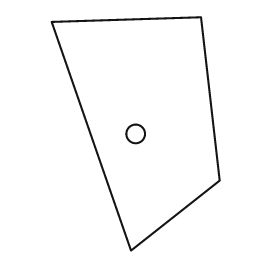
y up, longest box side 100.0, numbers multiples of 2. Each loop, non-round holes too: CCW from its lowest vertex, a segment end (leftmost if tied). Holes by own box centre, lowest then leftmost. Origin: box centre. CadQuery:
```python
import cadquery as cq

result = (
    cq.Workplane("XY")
    .moveTo(-2.0, -50.0)
    .lineTo(36.0, -20.0)
    .lineTo(28.0, 50.0)
    .lineTo(-36.0, 48.0)
    .close()
    .moveTo(0.0, 0.0)
    .circle(4.0)
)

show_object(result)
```